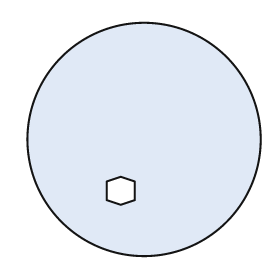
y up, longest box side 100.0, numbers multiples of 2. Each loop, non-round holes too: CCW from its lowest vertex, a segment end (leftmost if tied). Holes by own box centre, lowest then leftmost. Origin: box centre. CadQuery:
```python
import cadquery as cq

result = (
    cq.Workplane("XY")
    .moveTo(0.0, 0.0)
    .circle(50.0)
    .moveTo(-10.0, -28.0)
    .lineTo(-4.0, -26.0)
    .lineTo(-4.0, -18.0)
    .lineTo(-10.0, -16.0)
    .lineTo(-16.0, -18.0)
    .lineTo(-16.0, -26.0)
    .close()
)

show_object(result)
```